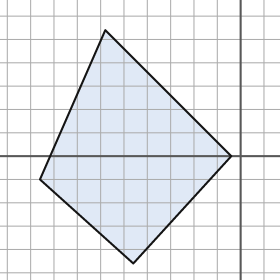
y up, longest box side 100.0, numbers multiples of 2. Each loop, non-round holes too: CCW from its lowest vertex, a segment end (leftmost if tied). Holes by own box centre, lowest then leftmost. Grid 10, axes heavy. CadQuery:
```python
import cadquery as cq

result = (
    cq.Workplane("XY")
    .moveTo(-46.0, -46.0)
    .lineTo(-4.0, 0.0)
    .lineTo(-58.0, 54.0)
    .lineTo(-86.0, -10.0)
    .close()
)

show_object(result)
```